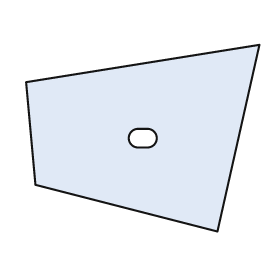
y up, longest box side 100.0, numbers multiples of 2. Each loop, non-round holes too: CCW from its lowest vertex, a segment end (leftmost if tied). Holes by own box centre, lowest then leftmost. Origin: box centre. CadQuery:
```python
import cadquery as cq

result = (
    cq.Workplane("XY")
    .moveTo(32.0, -40.0)
    .lineTo(50.0, 40.0)
    .lineTo(-50.0, 24.0)
    .lineTo(-46.0, -20.0)
    .close()
    .moveTo(-2.0, -4.0)
    .lineTo(2.0, -4.0)
    .threePointArc((6.0, 0.0), (2.0, 4.0))
    .lineTo(-2.0, 4.0)
    .threePointArc((-6.0, 0.0), (-2.0, -4.0))
    .close()
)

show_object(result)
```